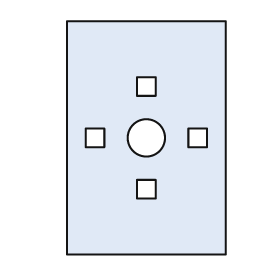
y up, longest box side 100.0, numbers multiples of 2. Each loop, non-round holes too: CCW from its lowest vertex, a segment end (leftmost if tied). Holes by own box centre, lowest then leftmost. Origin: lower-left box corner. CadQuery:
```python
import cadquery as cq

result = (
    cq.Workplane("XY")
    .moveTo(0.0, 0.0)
    .lineTo(68.0, 0.0)
    .lineTo(68.0, 100.0)
    .lineTo(0.0, 100.0)
    .close()
    .moveTo(30.0, 24.0)
    .lineTo(38.0, 24.0)
    .lineTo(38.0, 32.0)
    .lineTo(30.0, 32.0)
    .close()
    .moveTo(8.0, 46.0)
    .lineTo(16.0, 46.0)
    .lineTo(16.0, 54.0)
    .lineTo(8.0, 54.0)
    .close()
    .moveTo(34.0, 50.0)
    .circle(8.0)
    .moveTo(52.0, 46.0)
    .lineTo(60.0, 46.0)
    .lineTo(60.0, 54.0)
    .lineTo(52.0, 54.0)
    .close()
    .moveTo(30.0, 68.0)
    .lineTo(38.0, 68.0)
    .lineTo(38.0, 76.0)
    .lineTo(30.0, 76.0)
    .close()
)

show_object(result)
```